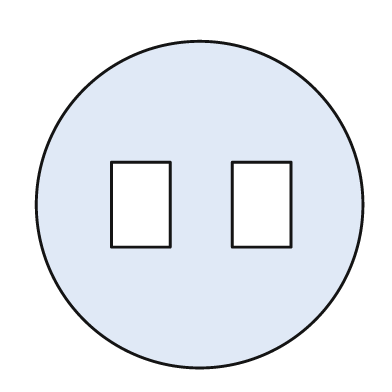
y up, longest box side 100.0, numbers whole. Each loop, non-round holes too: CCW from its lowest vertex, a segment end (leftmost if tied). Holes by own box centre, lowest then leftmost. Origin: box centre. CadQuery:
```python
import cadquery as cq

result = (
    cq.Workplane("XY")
    .moveTo(0.0, 0.0)
    .circle(50.0)
    .moveTo(-27.0, -13.0)
    .lineTo(-9.0, -13.0)
    .lineTo(-9.0, 13.0)
    .lineTo(-27.0, 13.0)
    .close()
    .moveTo(10.0, -13.0)
    .lineTo(28.0, -13.0)
    .lineTo(28.0, 13.0)
    .lineTo(10.0, 13.0)
    .close()
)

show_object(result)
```